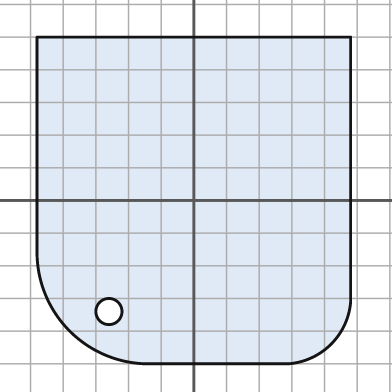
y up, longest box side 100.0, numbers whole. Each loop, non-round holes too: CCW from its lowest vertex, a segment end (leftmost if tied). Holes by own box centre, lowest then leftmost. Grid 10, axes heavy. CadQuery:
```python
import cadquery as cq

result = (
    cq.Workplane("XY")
    .moveTo(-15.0, -50.0)
    .lineTo(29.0, -50.0)
    .threePointArc((42.0, -44.0), (48.0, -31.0))
    .lineTo(48.0, 50.0)
    .lineTo(-48.0, 50.0)
    .lineTo(-48.0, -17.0)
    .threePointArc((-38.0, -40.0), (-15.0, -50.0))
    .close()
    .moveTo(-26.0, -34.0)
    .circle(4.0)
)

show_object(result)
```